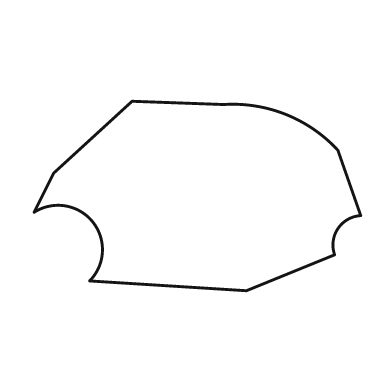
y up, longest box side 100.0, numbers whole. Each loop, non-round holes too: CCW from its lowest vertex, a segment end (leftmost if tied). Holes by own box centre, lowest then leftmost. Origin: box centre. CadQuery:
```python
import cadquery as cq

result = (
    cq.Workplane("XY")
    .moveTo(15.0, -29.0)
    .lineTo(42.0, -18.0)
    .threePointArc((43.0, -10.0), (50.0, -6.0))
    .lineTo(43.0, 14.0)
    .threePointArc((27.0, 25.0), (8.0, 28.0))
    .lineTo(-20.0, 29.0)
    .lineTo(-44.0, 7.0)
    .lineTo(-50.0, -5.0)
    .threePointArc((-32.0, -8.0), (-33.0, -26.0))
    .close()
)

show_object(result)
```